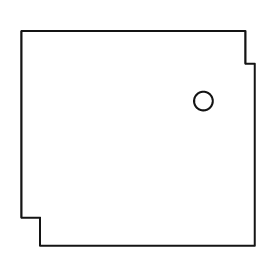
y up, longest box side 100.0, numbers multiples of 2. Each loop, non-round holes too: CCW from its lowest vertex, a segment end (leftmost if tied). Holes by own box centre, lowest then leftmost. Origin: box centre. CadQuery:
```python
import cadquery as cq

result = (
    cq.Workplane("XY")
    .moveTo(-42.0, -46.0)
    .lineTo(50.0, -46.0)
    .lineTo(50.0, 32.0)
    .lineTo(46.0, 32.0)
    .lineTo(46.0, 46.0)
    .lineTo(-50.0, 46.0)
    .lineTo(-50.0, -34.0)
    .lineTo(-42.0, -34.0)
    .close()
    .moveTo(28.0, 16.0)
    .circle(4.0)
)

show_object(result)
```